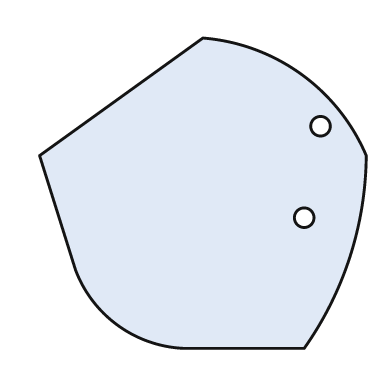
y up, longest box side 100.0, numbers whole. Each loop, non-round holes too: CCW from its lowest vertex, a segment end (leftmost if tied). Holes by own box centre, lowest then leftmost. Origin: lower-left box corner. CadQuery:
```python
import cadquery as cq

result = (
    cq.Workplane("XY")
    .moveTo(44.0, 0.0)
    .lineTo(81.0, 0.0)
    .threePointArc((95.0, 28.0), (100.0, 59.0))
    .threePointArc((80.0, 84.0), (50.0, 95.0))
    .lineTo(0.0, 59.0)
    .lineTo(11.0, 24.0)
    .threePointArc((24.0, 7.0), (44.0, 0.0))
    .close()
    .moveTo(81.0, 40.0)
    .circle(3.0)
    .moveTo(86.0, 68.0)
    .circle(3.0)
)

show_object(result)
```